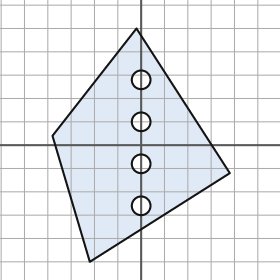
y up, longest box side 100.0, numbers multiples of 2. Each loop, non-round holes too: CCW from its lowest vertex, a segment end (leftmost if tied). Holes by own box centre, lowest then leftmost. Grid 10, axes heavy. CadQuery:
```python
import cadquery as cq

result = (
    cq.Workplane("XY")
    .moveTo(-22.0, -50.0)
    .lineTo(38.0, -12.0)
    .lineTo(-2.0, 50.0)
    .lineTo(-38.0, 4.0)
    .close()
    .moveTo(0.0, -26.0)
    .circle(4.0)
    .moveTo(0.0, -8.0)
    .circle(4.0)
    .moveTo(0.0, 10.0)
    .circle(4.0)
    .moveTo(0.0, 28.0)
    .circle(4.0)
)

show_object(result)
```